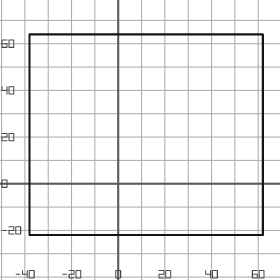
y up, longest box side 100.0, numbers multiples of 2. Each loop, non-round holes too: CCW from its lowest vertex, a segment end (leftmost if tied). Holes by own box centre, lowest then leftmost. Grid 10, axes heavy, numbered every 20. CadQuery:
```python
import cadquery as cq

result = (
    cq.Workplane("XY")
    .moveTo(-38.0, -22.0)
    .lineTo(62.0, -22.0)
    .lineTo(62.0, 64.0)
    .lineTo(-38.0, 64.0)
    .close()
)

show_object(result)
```